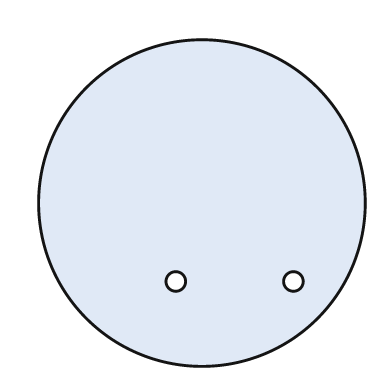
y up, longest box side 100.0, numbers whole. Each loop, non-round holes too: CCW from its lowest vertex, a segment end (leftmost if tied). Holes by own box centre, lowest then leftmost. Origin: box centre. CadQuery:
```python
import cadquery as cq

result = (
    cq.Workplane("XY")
    .moveTo(0.0, 0.0)
    .circle(50.0)
    .moveTo(-8.0, -24.0)
    .circle(3.0)
    .moveTo(28.0, -24.0)
    .circle(3.0)
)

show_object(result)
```